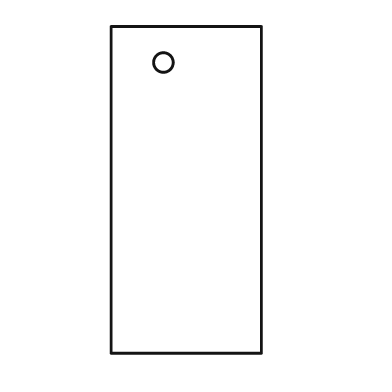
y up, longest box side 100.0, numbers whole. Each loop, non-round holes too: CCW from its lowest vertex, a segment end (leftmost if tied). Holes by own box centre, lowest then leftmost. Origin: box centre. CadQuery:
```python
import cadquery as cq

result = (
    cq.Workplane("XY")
    .moveTo(-23.0, -50.0)
    .lineTo(23.0, -50.0)
    .lineTo(23.0, 50.0)
    .lineTo(-23.0, 50.0)
    .close()
    .moveTo(-7.0, 39.0)
    .circle(3.0)
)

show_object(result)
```